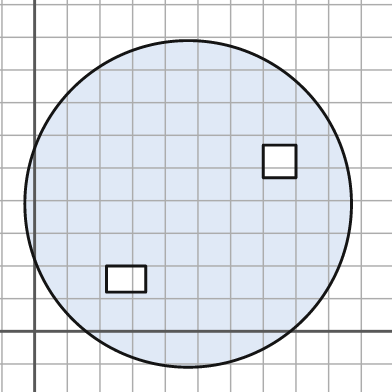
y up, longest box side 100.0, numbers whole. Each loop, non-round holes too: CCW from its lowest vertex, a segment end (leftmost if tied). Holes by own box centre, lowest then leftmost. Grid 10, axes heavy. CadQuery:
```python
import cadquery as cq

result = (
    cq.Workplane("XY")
    .moveTo(47.0, 39.0)
    .circle(50.0)
    .moveTo(22.0, 12.0)
    .lineTo(34.0, 12.0)
    .lineTo(34.0, 20.0)
    .lineTo(22.0, 20.0)
    .close()
    .moveTo(70.0, 47.0)
    .lineTo(80.0, 47.0)
    .lineTo(80.0, 57.0)
    .lineTo(70.0, 57.0)
    .close()
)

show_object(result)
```